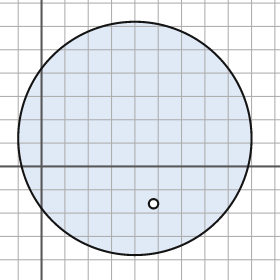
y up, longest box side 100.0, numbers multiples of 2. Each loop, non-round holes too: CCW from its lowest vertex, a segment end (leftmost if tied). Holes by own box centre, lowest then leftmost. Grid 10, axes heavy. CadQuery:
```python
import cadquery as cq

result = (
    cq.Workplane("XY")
    .moveTo(40.0, 12.0)
    .circle(50.0)
    .moveTo(48.0, -16.0)
    .circle(2.0)
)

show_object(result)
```